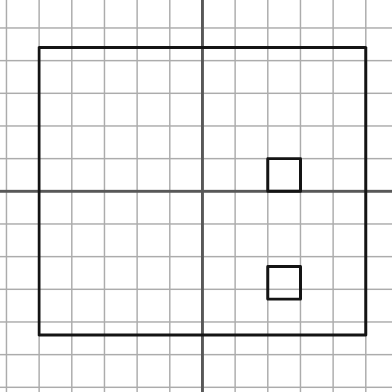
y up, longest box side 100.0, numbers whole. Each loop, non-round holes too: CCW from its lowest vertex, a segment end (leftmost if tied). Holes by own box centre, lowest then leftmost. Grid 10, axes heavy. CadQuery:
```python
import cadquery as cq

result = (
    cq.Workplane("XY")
    .moveTo(-50.0, -44.0)
    .lineTo(50.0, -44.0)
    .lineTo(50.0, 44.0)
    .lineTo(-50.0, 44.0)
    .close()
    .moveTo(20.0, -33.0)
    .lineTo(30.0, -33.0)
    .lineTo(30.0, -23.0)
    .lineTo(20.0, -23.0)
    .close()
    .moveTo(20.0, 0.0)
    .lineTo(30.0, 0.0)
    .lineTo(30.0, 10.0)
    .lineTo(20.0, 10.0)
    .close()
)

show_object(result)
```